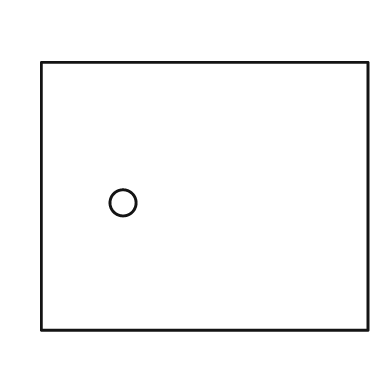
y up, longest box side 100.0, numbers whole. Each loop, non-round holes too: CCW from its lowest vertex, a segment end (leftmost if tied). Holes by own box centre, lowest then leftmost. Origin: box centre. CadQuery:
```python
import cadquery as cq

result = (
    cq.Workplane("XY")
    .moveTo(-50.0, -41.0)
    .lineTo(50.0, -41.0)
    .lineTo(50.0, 41.0)
    .lineTo(-50.0, 41.0)
    .close()
    .moveTo(-25.0, -2.0)
    .circle(4.0)
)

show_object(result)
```